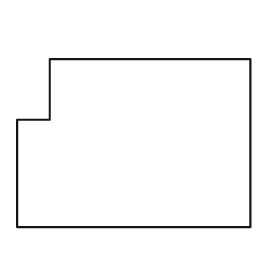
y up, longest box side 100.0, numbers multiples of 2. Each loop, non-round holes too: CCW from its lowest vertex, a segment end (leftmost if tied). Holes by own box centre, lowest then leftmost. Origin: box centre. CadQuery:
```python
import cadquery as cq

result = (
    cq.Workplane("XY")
    .moveTo(-50.0, -36.0)
    .lineTo(50.0, -36.0)
    .lineTo(50.0, 36.0)
    .lineTo(-36.0, 36.0)
    .lineTo(-36.0, 10.0)
    .lineTo(-50.0, 10.0)
    .close()
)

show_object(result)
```